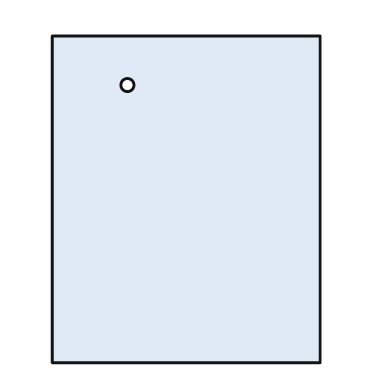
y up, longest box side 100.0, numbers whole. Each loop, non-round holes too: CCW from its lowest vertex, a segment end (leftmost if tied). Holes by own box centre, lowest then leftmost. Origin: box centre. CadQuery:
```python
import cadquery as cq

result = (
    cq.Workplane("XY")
    .moveTo(-41.0, -50.0)
    .lineTo(41.0, -50.0)
    .lineTo(41.0, 50.0)
    .lineTo(-41.0, 50.0)
    .close()
    .moveTo(-18.0, 35.0)
    .circle(2.0)
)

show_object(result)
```